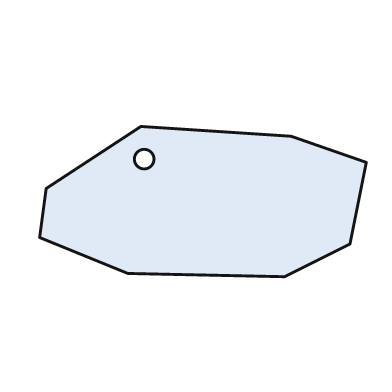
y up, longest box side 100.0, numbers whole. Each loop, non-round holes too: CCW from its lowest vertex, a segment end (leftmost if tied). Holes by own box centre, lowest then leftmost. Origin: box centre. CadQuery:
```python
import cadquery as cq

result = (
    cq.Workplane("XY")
    .moveTo(25.0, -23.0)
    .lineTo(45.0, -13.0)
    .lineTo(50.0, 12.0)
    .lineTo(27.0, 20.0)
    .lineTo(-19.0, 23.0)
    .lineTo(-48.0, 4.0)
    .lineTo(-50.0, -11.0)
    .lineTo(-23.0, -22.0)
    .close()
    .moveTo(-18.0, 13.0)
    .circle(3.0)
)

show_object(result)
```